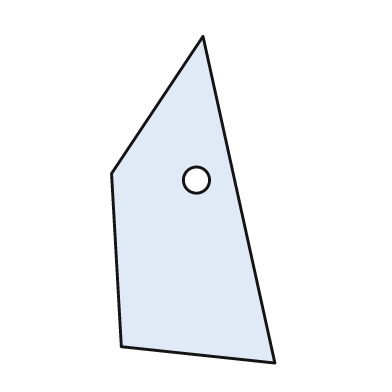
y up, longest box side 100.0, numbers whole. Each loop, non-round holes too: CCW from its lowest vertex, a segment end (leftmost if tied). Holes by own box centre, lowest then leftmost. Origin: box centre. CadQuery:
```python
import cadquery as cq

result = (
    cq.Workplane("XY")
    .moveTo(25.0, -50.0)
    .lineTo(3.0, 50.0)
    .lineTo(-25.0, 8.0)
    .lineTo(-22.0, -45.0)
    .close()
    .moveTo(1.0, 6.0)
    .circle(4.0)
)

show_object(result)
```